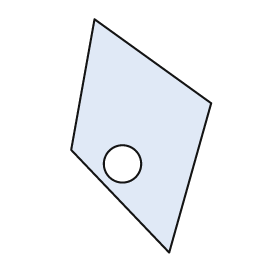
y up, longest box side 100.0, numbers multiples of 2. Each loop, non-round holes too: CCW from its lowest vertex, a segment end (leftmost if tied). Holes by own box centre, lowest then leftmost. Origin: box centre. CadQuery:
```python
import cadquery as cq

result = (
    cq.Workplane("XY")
    .moveTo(12.0, -50.0)
    .lineTo(30.0, 14.0)
    .lineTo(-20.0, 50.0)
    .lineTo(-30.0, -6.0)
    .close()
    .moveTo(-8.0, -12.0)
    .circle(8.0)
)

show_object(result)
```